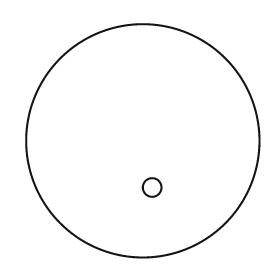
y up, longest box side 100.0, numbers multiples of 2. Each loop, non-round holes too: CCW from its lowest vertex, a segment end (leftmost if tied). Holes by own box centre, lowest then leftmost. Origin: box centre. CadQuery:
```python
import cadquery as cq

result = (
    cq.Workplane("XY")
    .moveTo(0.0, 0.0)
    .circle(50.0)
    .moveTo(4.0, -20.0)
    .circle(4.0)
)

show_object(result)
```